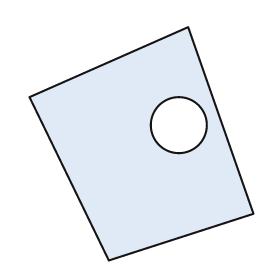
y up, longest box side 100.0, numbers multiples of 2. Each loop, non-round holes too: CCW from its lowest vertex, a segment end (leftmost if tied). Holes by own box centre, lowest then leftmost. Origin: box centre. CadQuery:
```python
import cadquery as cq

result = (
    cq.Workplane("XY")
    .moveTo(-14.0, -50.0)
    .lineTo(48.0, -30.0)
    .lineTo(20.0, 50.0)
    .lineTo(-48.0, 20.0)
    .close()
    .moveTo(16.0, 8.0)
    .circle(12.0)
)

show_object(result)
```